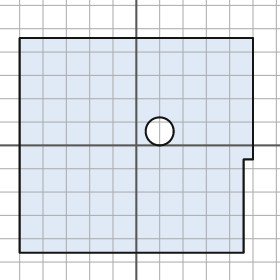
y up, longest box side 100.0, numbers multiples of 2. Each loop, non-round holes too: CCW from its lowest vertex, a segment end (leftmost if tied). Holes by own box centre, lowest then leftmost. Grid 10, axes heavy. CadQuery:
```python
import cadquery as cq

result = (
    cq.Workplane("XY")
    .moveTo(-50.0, -46.0)
    .lineTo(46.0, -46.0)
    .lineTo(46.0, -6.0)
    .lineTo(50.0, -6.0)
    .lineTo(50.0, 46.0)
    .lineTo(-50.0, 46.0)
    .close()
    .moveTo(10.0, 6.0)
    .circle(6.0)
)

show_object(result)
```